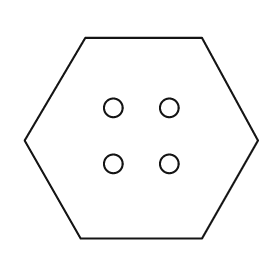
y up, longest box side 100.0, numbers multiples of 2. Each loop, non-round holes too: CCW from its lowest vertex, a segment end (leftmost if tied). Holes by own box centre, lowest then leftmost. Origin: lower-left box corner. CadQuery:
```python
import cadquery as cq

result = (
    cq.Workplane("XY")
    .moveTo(24.0, 0.0)
    .lineTo(76.0, 0.0)
    .lineTo(100.0, 42.0)
    .lineTo(76.0, 86.0)
    .lineTo(26.0, 86.0)
    .lineTo(0.0, 42.0)
    .close()
    .moveTo(38.0, 32.0)
    .circle(4.0)
    .moveTo(62.0, 32.0)
    .circle(4.0)
    .moveTo(38.0, 56.0)
    .circle(4.0)
    .moveTo(62.0, 56.0)
    .circle(4.0)
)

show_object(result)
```